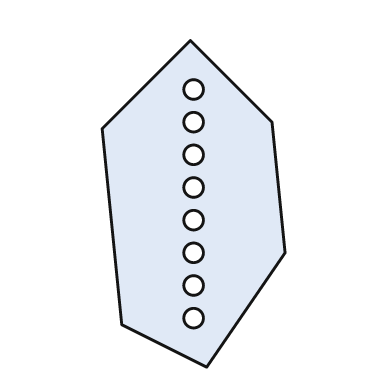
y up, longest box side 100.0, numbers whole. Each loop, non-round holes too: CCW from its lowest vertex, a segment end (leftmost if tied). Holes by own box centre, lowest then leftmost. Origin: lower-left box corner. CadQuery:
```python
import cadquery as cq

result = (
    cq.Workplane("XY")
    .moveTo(32.0, 0.0)
    .lineTo(56.0, 35.0)
    .lineTo(52.0, 75.0)
    .lineTo(27.0, 100.0)
    .lineTo(0.0, 73.0)
    .lineTo(6.0, 13.0)
    .close()
    .moveTo(28.0, 15.0)
    .circle(3.0)
    .moveTo(28.0, 25.0)
    .circle(3.0)
    .moveTo(28.0, 35.0)
    .circle(3.0)
    .moveTo(28.0, 45.0)
    .circle(3.0)
    .moveTo(28.0, 55.0)
    .circle(3.0)
    .moveTo(28.0, 65.0)
    .circle(3.0)
    .moveTo(28.0, 75.0)
    .circle(3.0)
    .moveTo(28.0, 85.0)
    .circle(3.0)
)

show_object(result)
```